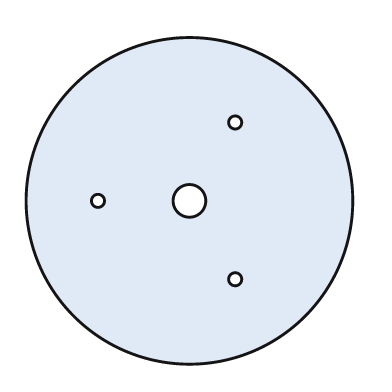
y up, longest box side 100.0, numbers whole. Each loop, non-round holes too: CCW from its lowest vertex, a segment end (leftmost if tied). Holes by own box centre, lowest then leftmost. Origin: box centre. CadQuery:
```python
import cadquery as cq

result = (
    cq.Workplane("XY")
    .moveTo(0.0, 0.0)
    .circle(50.0)
    .moveTo(14.0, -24.0)
    .circle(2.0)
    .moveTo(-28.0, 0.0)
    .circle(2.0)
    .moveTo(0.0, 0.0)
    .circle(5.0)
    .moveTo(14.0, 24.0)
    .circle(2.0)
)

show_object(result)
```